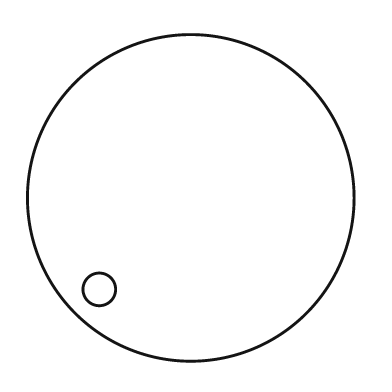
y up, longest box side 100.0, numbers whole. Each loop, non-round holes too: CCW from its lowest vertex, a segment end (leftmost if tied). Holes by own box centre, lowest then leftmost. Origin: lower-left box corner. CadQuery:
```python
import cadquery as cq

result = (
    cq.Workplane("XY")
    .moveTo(50.0, 50.0)
    .circle(50.0)
    .moveTo(22.0, 22.0)
    .circle(5.0)
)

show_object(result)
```